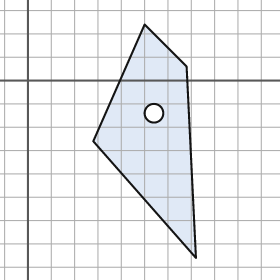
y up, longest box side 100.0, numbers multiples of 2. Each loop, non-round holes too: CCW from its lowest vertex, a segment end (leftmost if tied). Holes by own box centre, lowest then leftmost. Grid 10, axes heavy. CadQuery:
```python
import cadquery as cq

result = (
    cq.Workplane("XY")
    .moveTo(72.0, -76.0)
    .lineTo(68.0, 6.0)
    .lineTo(50.0, 24.0)
    .lineTo(28.0, -26.0)
    .close()
    .moveTo(54.0, -14.0)
    .circle(4.0)
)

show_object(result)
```